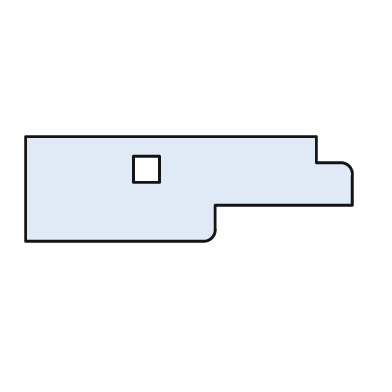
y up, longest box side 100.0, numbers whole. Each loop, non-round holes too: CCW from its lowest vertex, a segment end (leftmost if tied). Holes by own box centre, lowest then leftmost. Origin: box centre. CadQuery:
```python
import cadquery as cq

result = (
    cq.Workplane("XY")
    .moveTo(-50.0, -16.0)
    .lineTo(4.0, -16.0)
    .threePointArc((7.0, -15.0), (8.0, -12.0))
    .lineTo(8.0, -5.0)
    .lineTo(50.0, -5.0)
    .lineTo(50.0, 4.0)
    .threePointArc((49.0, 7.0), (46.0, 8.0))
    .lineTo(39.0, 8.0)
    .lineTo(39.0, 16.0)
    .lineTo(-50.0, 16.0)
    .close()
    .moveTo(-17.0, 2.0)
    .lineTo(-9.0, 2.0)
    .lineTo(-9.0, 10.0)
    .lineTo(-17.0, 10.0)
    .close()
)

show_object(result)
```